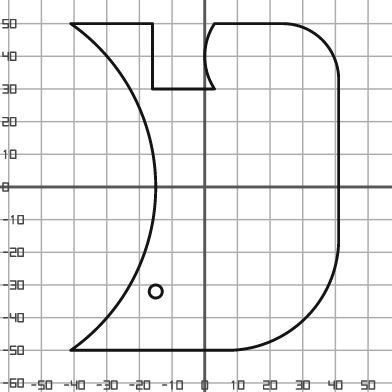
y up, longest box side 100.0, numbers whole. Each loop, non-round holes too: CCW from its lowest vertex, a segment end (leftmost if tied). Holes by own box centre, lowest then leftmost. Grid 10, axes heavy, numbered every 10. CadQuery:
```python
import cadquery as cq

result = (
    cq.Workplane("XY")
    .moveTo(-41.0, -50.0)
    .lineTo(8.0, -50.0)
    .threePointArc((31.0, -40.0), (41.0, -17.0))
    .lineTo(41.0, 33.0)
    .threePointArc((36.0, 45.0), (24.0, 50.0))
    .lineTo(3.0, 50.0)
    .threePointArc((0.0, 40.0), (3.0, 30.0))
    .lineTo(-16.0, 30.0)
    .lineTo(-16.0, 50.0)
    .lineTo(-41.0, 50.0)
    .threePointArc((-15.0, 0.0), (-41.0, -50.0))
    .close()
    .moveTo(-15.0, -32.0)
    .circle(2.0)
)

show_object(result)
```